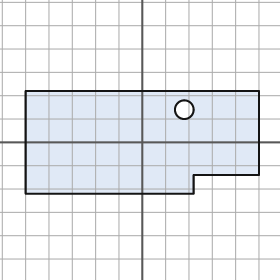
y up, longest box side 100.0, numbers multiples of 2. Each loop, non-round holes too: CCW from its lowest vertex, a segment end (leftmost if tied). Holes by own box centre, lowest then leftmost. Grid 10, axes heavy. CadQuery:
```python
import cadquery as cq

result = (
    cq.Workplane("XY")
    .moveTo(-50.0, -22.0)
    .lineTo(22.0, -22.0)
    .lineTo(22.0, -14.0)
    .lineTo(50.0, -14.0)
    .lineTo(50.0, 22.0)
    .lineTo(-50.0, 22.0)
    .close()
    .moveTo(18.0, 14.0)
    .circle(4.0)
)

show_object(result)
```